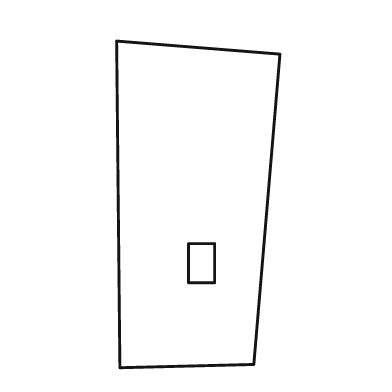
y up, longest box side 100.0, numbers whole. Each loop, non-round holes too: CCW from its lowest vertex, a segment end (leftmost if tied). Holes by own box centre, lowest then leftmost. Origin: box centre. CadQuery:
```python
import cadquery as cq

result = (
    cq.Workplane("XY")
    .moveTo(-24.0, -50.0)
    .lineTo(17.0, -49.0)
    .lineTo(25.0, 46.0)
    .lineTo(-25.0, 50.0)
    .close()
    .moveTo(-3.0, -24.0)
    .lineTo(5.0, -24.0)
    .lineTo(5.0, -12.0)
    .lineTo(-3.0, -12.0)
    .close()
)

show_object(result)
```